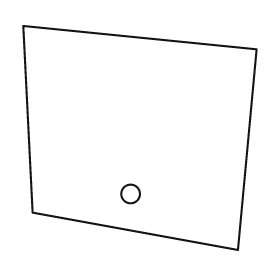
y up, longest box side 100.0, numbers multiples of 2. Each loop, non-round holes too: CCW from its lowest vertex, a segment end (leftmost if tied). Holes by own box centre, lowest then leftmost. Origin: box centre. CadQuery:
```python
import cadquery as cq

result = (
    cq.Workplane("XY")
    .moveTo(42.0, -48.0)
    .lineTo(50.0, 38.0)
    .lineTo(-50.0, 48.0)
    .lineTo(-46.0, -32.0)
    .close()
    .moveTo(-4.0, -24.0)
    .circle(4.0)
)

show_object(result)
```